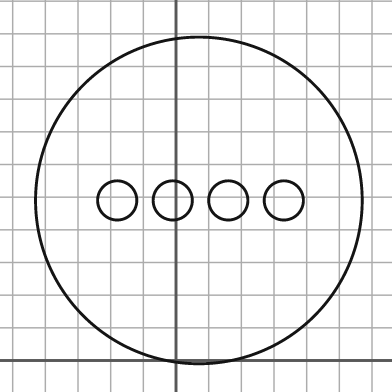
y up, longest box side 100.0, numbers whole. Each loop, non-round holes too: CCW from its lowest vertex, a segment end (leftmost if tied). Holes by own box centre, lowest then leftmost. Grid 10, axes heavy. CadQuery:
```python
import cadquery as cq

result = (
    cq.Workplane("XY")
    .moveTo(7.0, 49.0)
    .circle(50.0)
    .moveTo(-18.0, 49.0)
    .circle(6.0)
    .moveTo(-1.0, 49.0)
    .circle(6.0)
    .moveTo(16.0, 49.0)
    .circle(6.0)
    .moveTo(33.0, 49.0)
    .circle(6.0)
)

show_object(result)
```